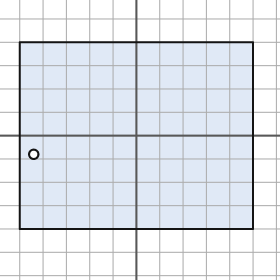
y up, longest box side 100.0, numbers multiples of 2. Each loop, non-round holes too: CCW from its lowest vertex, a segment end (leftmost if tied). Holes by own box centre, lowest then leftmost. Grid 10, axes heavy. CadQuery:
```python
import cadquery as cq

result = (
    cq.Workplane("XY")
    .moveTo(-50.0, -40.0)
    .lineTo(50.0, -40.0)
    .lineTo(50.0, 40.0)
    .lineTo(-50.0, 40.0)
    .close()
    .moveTo(-44.0, -8.0)
    .circle(2.0)
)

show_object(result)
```